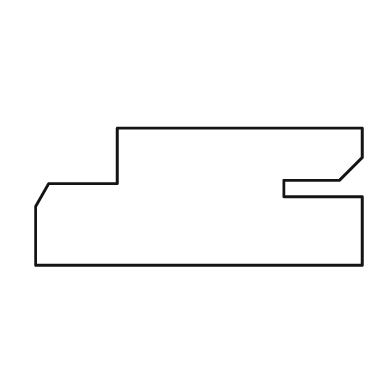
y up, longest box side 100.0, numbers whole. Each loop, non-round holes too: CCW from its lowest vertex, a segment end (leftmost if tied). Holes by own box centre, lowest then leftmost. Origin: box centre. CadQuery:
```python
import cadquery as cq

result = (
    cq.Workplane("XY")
    .moveTo(-50.0, -21.0)
    .lineTo(50.0, -21.0)
    .lineTo(50.0, 0.0)
    .lineTo(26.0, 0.0)
    .lineTo(26.0, 5.0)
    .lineTo(43.0, 5.0)
    .lineTo(50.0, 12.0)
    .lineTo(50.0, 21.0)
    .lineTo(-25.0, 21.0)
    .lineTo(-25.0, 4.0)
    .lineTo(-46.0, 4.0)
    .lineTo(-50.0, -3.0)
    .close()
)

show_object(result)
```